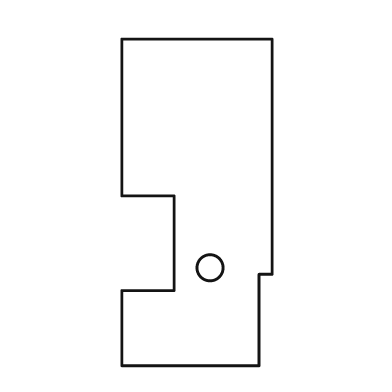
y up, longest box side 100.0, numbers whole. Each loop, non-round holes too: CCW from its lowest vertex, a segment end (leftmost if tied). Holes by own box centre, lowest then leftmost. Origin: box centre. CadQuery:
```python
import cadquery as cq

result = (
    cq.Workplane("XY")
    .moveTo(-23.0, -50.0)
    .lineTo(19.0, -50.0)
    .lineTo(19.0, -22.0)
    .lineTo(23.0, -22.0)
    .lineTo(23.0, 50.0)
    .lineTo(-23.0, 50.0)
    .lineTo(-23.0, 2.0)
    .lineTo(-7.0, 2.0)
    .lineTo(-7.0, -27.0)
    .lineTo(-23.0, -27.0)
    .close()
    .moveTo(4.0, -20.0)
    .circle(4.0)
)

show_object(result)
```